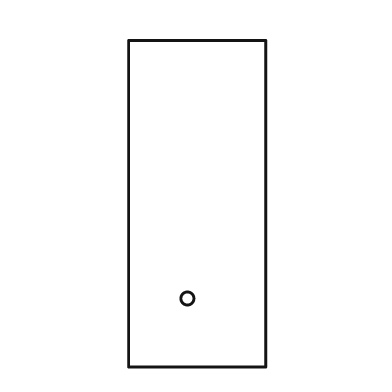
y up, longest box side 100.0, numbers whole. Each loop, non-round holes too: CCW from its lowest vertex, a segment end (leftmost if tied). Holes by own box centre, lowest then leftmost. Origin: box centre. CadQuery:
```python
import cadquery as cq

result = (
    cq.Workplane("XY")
    .moveTo(-21.0, -50.0)
    .lineTo(21.0, -50.0)
    .lineTo(21.0, 50.0)
    .lineTo(-21.0, 50.0)
    .close()
    .moveTo(-3.0, -29.0)
    .circle(2.0)
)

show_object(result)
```